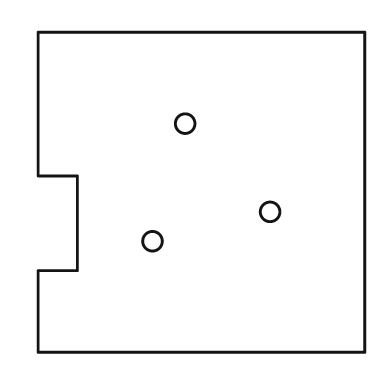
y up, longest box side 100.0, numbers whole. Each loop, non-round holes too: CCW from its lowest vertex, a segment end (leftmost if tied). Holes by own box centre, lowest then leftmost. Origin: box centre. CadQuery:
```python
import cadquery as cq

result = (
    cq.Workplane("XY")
    .moveTo(-50.0, -49.0)
    .lineTo(50.0, -49.0)
    .lineTo(50.0, 49.0)
    .lineTo(-50.0, 49.0)
    .lineTo(-50.0, 5.0)
    .lineTo(-38.0, 5.0)
    .lineTo(-38.0, -24.0)
    .lineTo(-50.0, -24.0)
    .close()
    .moveTo(-15.0, -15.0)
    .circle(3.0)
    .moveTo(21.0, -6.0)
    .circle(3.0)
    .moveTo(-5.0, 21.0)
    .circle(3.0)
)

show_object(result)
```